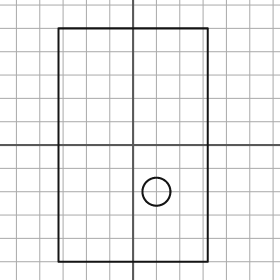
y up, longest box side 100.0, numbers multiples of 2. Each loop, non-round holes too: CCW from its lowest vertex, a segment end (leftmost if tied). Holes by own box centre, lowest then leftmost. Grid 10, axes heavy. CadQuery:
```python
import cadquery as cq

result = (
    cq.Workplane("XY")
    .moveTo(-32.0, -50.0)
    .lineTo(32.0, -50.0)
    .lineTo(32.0, 50.0)
    .lineTo(-32.0, 50.0)
    .close()
    .moveTo(10.0, -20.0)
    .circle(6.0)
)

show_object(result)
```